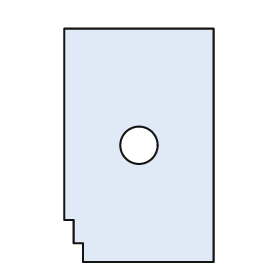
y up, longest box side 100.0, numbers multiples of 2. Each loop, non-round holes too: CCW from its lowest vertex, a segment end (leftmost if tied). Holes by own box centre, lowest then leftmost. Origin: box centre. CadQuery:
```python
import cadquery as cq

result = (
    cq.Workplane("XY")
    .moveTo(-24.0, -50.0)
    .lineTo(32.0, -50.0)
    .lineTo(32.0, 50.0)
    .lineTo(-32.0, 50.0)
    .lineTo(-32.0, -32.0)
    .lineTo(-28.0, -32.0)
    .lineTo(-28.0, -42.0)
    .lineTo(-24.0, -42.0)
    .close()
    .moveTo(0.0, 0.0)
    .circle(8.0)
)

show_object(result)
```